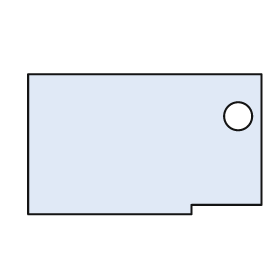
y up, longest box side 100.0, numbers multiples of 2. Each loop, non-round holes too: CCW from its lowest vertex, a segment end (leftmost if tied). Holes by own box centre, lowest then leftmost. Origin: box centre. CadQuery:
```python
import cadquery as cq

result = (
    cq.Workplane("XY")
    .moveTo(-50.0, -30.0)
    .lineTo(20.0, -30.0)
    .lineTo(20.0, -26.0)
    .lineTo(50.0, -26.0)
    .lineTo(50.0, 30.0)
    .lineTo(-50.0, 30.0)
    .close()
    .moveTo(40.0, 12.0)
    .circle(6.0)
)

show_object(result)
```